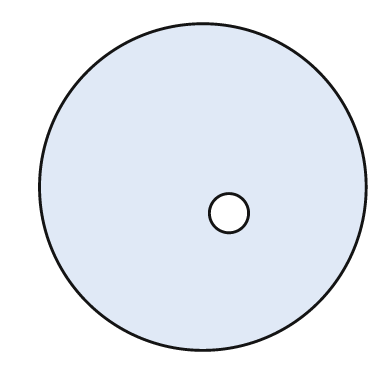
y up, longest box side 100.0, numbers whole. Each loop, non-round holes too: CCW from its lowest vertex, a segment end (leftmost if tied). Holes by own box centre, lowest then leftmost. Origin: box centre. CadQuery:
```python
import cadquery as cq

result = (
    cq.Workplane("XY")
    .moveTo(0.0, 0.0)
    .circle(50.0)
    .moveTo(8.0, -8.0)
    .circle(6.0)
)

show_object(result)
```